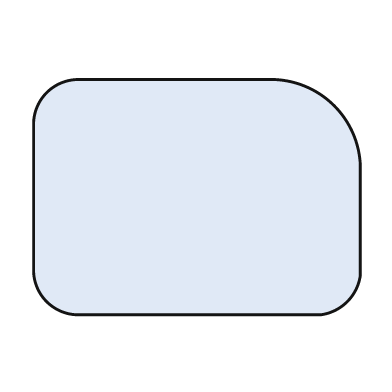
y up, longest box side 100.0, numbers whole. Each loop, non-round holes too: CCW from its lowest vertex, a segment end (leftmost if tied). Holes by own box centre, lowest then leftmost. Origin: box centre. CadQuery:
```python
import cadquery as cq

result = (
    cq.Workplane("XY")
    .moveTo(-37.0, -36.0)
    .lineTo(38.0, -36.0)
    .threePointArc((46.0, -32.0), (50.0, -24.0))
    .lineTo(50.0, 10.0)
    .threePointArc((42.0, 28.0), (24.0, 36.0))
    .lineTo(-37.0, 36.0)
    .threePointArc((-46.0, 32.0), (-50.0, 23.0))
    .lineTo(-50.0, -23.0)
    .threePointArc((-46.0, -32.0), (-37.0, -36.0))
    .close()
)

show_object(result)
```